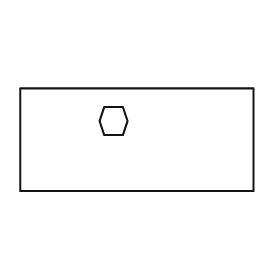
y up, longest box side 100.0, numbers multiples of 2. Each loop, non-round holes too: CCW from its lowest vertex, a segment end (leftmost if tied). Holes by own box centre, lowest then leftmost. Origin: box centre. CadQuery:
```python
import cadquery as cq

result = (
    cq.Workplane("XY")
    .moveTo(-50.0, -22.0)
    .lineTo(50.0, -22.0)
    .lineTo(50.0, 22.0)
    .lineTo(-50.0, 22.0)
    .close()
    .moveTo(-14.0, 2.0)
    .lineTo(-6.0, 2.0)
    .lineTo(-4.0, 8.0)
    .lineTo(-6.0, 14.0)
    .lineTo(-14.0, 14.0)
    .lineTo(-16.0, 8.0)
    .close()
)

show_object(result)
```